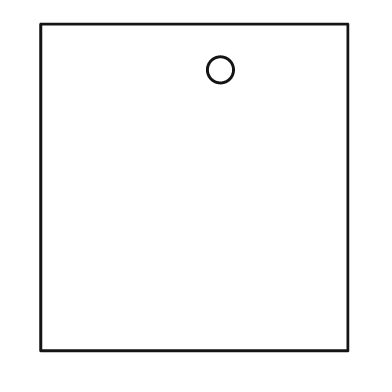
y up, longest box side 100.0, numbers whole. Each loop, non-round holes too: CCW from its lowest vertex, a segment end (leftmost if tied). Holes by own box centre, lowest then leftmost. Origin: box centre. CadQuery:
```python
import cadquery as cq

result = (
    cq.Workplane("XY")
    .moveTo(-47.0, -50.0)
    .lineTo(47.0, -50.0)
    .lineTo(47.0, 50.0)
    .lineTo(-47.0, 50.0)
    .close()
    .moveTo(8.0, 36.0)
    .circle(4.0)
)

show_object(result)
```